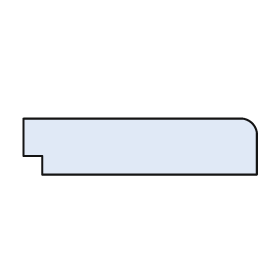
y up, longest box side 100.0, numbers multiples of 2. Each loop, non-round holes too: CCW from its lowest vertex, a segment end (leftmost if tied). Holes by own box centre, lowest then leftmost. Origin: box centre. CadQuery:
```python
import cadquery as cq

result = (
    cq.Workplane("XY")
    .moveTo(-42.0, -12.0)
    .lineTo(50.0, -12.0)
    .lineTo(50.0, 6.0)
    .threePointArc((48.0, 10.0), (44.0, 12.0))
    .lineTo(-50.0, 12.0)
    .lineTo(-50.0, -4.0)
    .lineTo(-42.0, -4.0)
    .close()
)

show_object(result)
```